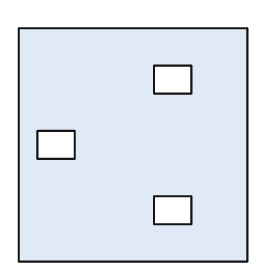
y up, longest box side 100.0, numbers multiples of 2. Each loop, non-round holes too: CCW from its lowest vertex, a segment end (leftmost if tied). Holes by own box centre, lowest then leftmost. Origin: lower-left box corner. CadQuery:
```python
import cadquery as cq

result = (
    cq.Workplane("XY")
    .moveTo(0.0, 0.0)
    .lineTo(98.0, 0.0)
    .lineTo(98.0, 100.0)
    .lineTo(0.0, 100.0)
    .close()
    .moveTo(58.0, 16.0)
    .lineTo(74.0, 16.0)
    .lineTo(74.0, 28.0)
    .lineTo(58.0, 28.0)
    .close()
    .moveTo(8.0, 44.0)
    .lineTo(24.0, 44.0)
    .lineTo(24.0, 56.0)
    .lineTo(8.0, 56.0)
    .close()
    .moveTo(58.0, 72.0)
    .lineTo(74.0, 72.0)
    .lineTo(74.0, 84.0)
    .lineTo(58.0, 84.0)
    .close()
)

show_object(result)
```